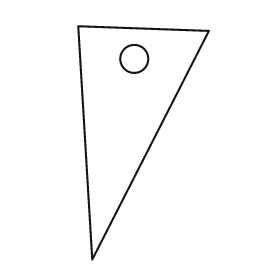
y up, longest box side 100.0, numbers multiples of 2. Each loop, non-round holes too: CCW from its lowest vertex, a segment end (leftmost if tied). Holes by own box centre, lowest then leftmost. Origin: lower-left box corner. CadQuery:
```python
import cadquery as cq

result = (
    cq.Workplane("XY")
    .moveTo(6.0, 0.0)
    .lineTo(56.0, 98.0)
    .lineTo(0.0, 100.0)
    .close()
    .moveTo(24.0, 86.0)
    .circle(6.0)
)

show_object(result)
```